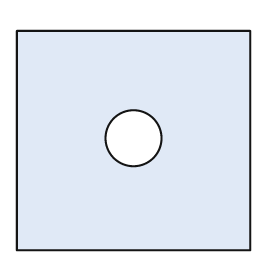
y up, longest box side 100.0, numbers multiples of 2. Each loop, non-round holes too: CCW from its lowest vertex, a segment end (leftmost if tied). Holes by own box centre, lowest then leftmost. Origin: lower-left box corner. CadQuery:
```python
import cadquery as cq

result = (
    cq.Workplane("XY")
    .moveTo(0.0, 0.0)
    .lineTo(100.0, 0.0)
    .lineTo(100.0, 94.0)
    .lineTo(0.0, 94.0)
    .close()
    .moveTo(50.0, 48.0)
    .circle(12.0)
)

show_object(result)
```